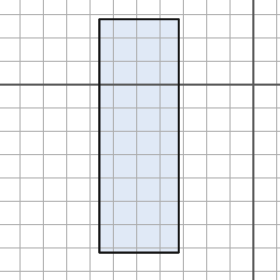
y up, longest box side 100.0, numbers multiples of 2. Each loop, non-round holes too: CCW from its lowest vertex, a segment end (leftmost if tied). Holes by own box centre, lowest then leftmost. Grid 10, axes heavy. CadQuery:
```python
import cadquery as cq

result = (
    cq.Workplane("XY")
    .moveTo(-66.0, -72.0)
    .lineTo(-32.0, -72.0)
    .lineTo(-32.0, 28.0)
    .lineTo(-66.0, 28.0)
    .close()
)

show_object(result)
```